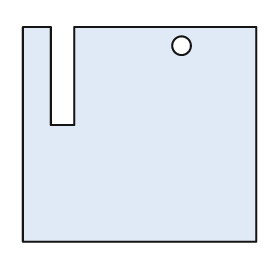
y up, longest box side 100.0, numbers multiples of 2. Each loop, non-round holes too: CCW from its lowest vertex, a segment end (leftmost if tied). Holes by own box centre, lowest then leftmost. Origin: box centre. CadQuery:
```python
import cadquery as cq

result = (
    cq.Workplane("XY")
    .moveTo(-50.0, -46.0)
    .lineTo(50.0, -46.0)
    .lineTo(50.0, 46.0)
    .lineTo(-28.0, 46.0)
    .lineTo(-28.0, 4.0)
    .lineTo(-38.0, 4.0)
    .lineTo(-38.0, 46.0)
    .lineTo(-50.0, 46.0)
    .close()
    .moveTo(18.0, 38.0)
    .circle(4.0)
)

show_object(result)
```